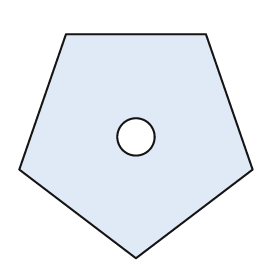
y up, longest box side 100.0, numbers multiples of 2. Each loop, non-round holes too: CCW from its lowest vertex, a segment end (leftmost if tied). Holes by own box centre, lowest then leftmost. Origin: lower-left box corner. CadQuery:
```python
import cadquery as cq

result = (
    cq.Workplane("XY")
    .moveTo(50.0, 0.0)
    .lineTo(100.0, 38.0)
    .lineTo(80.0, 96.0)
    .lineTo(20.0, 96.0)
    .lineTo(0.0, 38.0)
    .close()
    .moveTo(50.0, 52.0)
    .circle(8.0)
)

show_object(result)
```